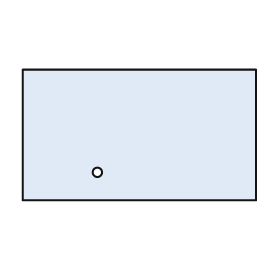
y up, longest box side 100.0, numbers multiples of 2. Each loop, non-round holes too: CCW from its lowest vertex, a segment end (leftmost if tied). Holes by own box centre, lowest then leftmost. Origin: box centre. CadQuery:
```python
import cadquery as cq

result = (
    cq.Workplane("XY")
    .moveTo(-50.0, -28.0)
    .lineTo(50.0, -28.0)
    .lineTo(50.0, 28.0)
    .lineTo(-50.0, 28.0)
    .close()
    .moveTo(-18.0, -16.0)
    .circle(2.0)
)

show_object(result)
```